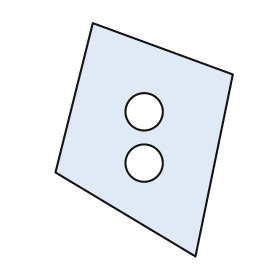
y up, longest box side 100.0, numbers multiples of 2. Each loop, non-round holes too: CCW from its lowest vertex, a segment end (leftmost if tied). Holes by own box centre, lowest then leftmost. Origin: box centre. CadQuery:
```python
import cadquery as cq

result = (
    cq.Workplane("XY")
    .moveTo(22.0, -50.0)
    .lineTo(38.0, 28.0)
    .lineTo(-22.0, 50.0)
    .lineTo(-38.0, -14.0)
    .close()
    .moveTo(0.0, -10.0)
    .circle(8.0)
    .moveTo(0.0, 12.0)
    .circle(8.0)
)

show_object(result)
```